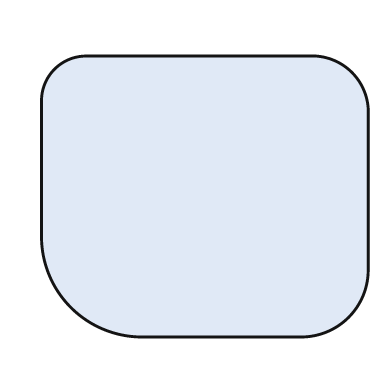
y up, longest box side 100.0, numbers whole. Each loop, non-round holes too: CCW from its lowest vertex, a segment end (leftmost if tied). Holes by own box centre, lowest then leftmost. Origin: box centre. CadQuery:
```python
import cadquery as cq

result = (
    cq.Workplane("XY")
    .moveTo(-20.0, -43.0)
    .lineTo(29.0, -43.0)
    .threePointArc((44.0, -37.0), (50.0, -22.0))
    .lineTo(50.0, 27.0)
    .threePointArc((45.0, 38.0), (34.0, 43.0))
    .lineTo(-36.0, 43.0)
    .threePointArc((-46.0, 39.0), (-50.0, 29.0))
    .lineTo(-50.0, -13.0)
    .threePointArc((-41.0, -34.0), (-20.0, -43.0))
    .close()
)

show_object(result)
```